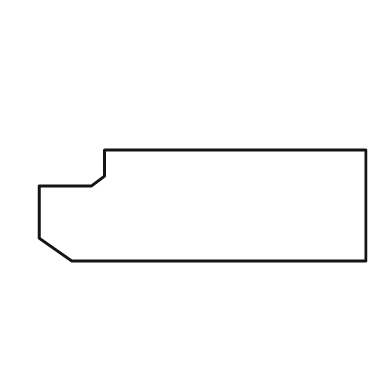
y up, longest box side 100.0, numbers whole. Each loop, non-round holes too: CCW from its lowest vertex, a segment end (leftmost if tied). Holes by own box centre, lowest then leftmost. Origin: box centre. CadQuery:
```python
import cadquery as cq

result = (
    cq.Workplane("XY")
    .moveTo(-40.0, -17.0)
    .lineTo(50.0, -17.0)
    .lineTo(50.0, 17.0)
    .lineTo(-30.0, 17.0)
    .lineTo(-30.0, 9.0)
    .lineTo(-34.0, 6.0)
    .lineTo(-50.0, 6.0)
    .lineTo(-50.0, -10.0)
    .close()
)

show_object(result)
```